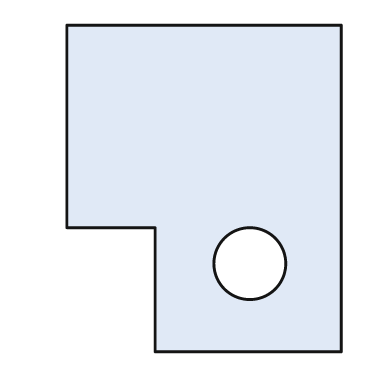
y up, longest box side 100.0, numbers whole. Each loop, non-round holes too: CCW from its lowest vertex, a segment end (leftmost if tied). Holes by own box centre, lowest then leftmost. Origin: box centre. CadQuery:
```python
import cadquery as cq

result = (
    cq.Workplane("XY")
    .moveTo(-15.0, -50.0)
    .lineTo(42.0, -50.0)
    .lineTo(42.0, 50.0)
    .lineTo(-42.0, 50.0)
    .lineTo(-42.0, -12.0)
    .lineTo(-15.0, -12.0)
    .close()
    .moveTo(14.0, -23.0)
    .circle(11.0)
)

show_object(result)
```